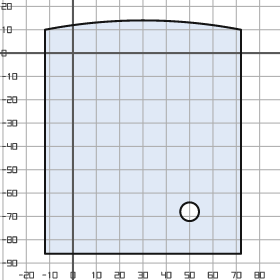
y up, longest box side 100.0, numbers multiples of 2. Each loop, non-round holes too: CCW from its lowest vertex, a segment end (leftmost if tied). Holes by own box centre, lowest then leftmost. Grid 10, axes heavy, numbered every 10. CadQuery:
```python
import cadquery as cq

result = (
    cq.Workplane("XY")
    .moveTo(-12.0, -86.0)
    .lineTo(72.0, -86.0)
    .lineTo(72.0, 10.0)
    .threePointArc((30.0, 14.0), (-12.0, 10.0))
    .close()
    .moveTo(50.0, -68.0)
    .circle(4.0)
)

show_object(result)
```